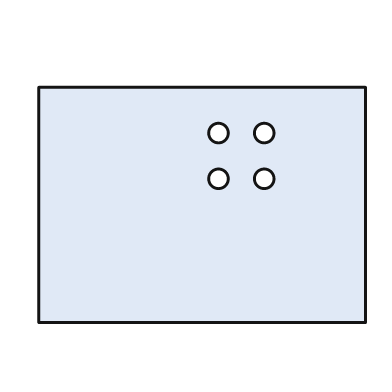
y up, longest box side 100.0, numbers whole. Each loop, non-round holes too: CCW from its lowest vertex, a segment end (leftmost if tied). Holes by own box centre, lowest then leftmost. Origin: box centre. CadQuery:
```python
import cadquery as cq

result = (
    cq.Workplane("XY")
    .moveTo(-50.0, -36.0)
    .lineTo(50.0, -36.0)
    .lineTo(50.0, 36.0)
    .lineTo(-50.0, 36.0)
    .close()
    .moveTo(5.0, 8.0)
    .circle(3.0)
    .moveTo(19.0, 8.0)
    .circle(3.0)
    .moveTo(5.0, 22.0)
    .circle(3.0)
    .moveTo(19.0, 22.0)
    .circle(3.0)
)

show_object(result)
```